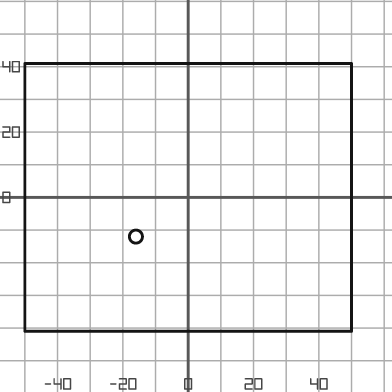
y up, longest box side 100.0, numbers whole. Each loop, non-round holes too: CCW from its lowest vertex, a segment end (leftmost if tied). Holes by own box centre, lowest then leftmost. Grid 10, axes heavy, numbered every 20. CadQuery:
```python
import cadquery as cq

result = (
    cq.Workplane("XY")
    .moveTo(-50.0, -41.0)
    .lineTo(50.0, -41.0)
    .lineTo(50.0, 41.0)
    .lineTo(-50.0, 41.0)
    .close()
    .moveTo(-16.0, -12.0)
    .circle(2.0)
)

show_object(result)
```